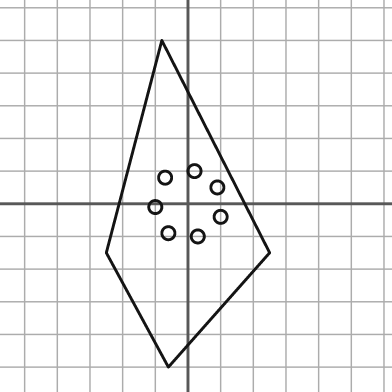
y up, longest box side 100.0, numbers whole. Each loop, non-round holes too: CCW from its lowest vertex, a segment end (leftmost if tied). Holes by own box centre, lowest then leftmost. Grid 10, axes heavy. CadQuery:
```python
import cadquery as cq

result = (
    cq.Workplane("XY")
    .moveTo(-6.0, -50.0)
    .lineTo(25.0, -15.0)
    .lineTo(-8.0, 50.0)
    .lineTo(-25.0, -15.0)
    .close()
    .moveTo(3.0, -10.0)
    .circle(2.0)
    .moveTo(-6.0, -9.0)
    .circle(2.0)
    .moveTo(10.0, -4.0)
    .circle(2.0)
    .moveTo(-10.0, -1.0)
    .circle(2.0)
    .moveTo(9.0, 5.0)
    .circle(2.0)
    .moveTo(-7.0, 8.0)
    .circle(2.0)
    .moveTo(2.0, 10.0)
    .circle(2.0)
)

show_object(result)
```